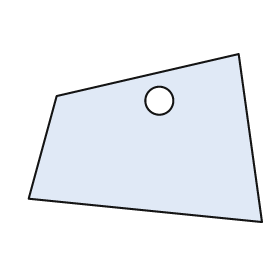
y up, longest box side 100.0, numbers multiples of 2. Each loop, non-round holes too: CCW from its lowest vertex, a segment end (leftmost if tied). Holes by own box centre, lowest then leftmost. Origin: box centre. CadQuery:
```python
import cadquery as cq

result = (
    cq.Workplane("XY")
    .moveTo(50.0, -36.0)
    .lineTo(40.0, 36.0)
    .lineTo(-38.0, 18.0)
    .lineTo(-50.0, -26.0)
    .close()
    .moveTo(6.0, 16.0)
    .circle(6.0)
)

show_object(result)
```